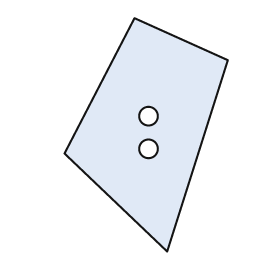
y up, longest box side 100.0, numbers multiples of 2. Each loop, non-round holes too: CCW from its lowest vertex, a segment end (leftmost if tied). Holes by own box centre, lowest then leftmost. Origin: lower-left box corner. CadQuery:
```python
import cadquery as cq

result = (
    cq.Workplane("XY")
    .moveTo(44.0, 0.0)
    .lineTo(70.0, 82.0)
    .lineTo(30.0, 100.0)
    .lineTo(0.0, 42.0)
    .close()
    .moveTo(36.0, 44.0)
    .circle(4.0)
    .moveTo(36.0, 58.0)
    .circle(4.0)
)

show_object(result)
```